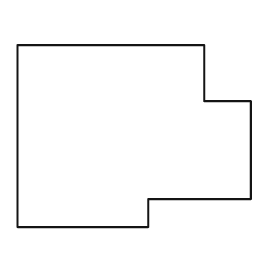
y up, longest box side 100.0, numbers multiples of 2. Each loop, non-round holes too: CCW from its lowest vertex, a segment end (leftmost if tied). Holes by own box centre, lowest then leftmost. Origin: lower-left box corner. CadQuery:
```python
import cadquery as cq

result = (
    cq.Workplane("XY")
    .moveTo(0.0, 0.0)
    .lineTo(56.0, 0.0)
    .lineTo(56.0, 12.0)
    .lineTo(100.0, 12.0)
    .lineTo(100.0, 54.0)
    .lineTo(80.0, 54.0)
    .lineTo(80.0, 78.0)
    .lineTo(0.0, 78.0)
    .close()
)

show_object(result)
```